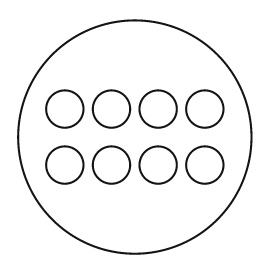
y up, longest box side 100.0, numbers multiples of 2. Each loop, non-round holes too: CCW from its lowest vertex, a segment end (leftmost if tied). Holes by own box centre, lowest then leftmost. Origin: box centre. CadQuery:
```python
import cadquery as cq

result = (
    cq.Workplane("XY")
    .moveTo(0.0, 0.0)
    .circle(50.0)
    .moveTo(-30.0, -12.0)
    .circle(8.0)
    .moveTo(-10.0, -12.0)
    .circle(8.0)
    .moveTo(10.0, -12.0)
    .circle(8.0)
    .moveTo(30.0, -12.0)
    .circle(8.0)
    .moveTo(-30.0, 12.0)
    .circle(8.0)
    .moveTo(-10.0, 12.0)
    .circle(8.0)
    .moveTo(10.0, 12.0)
    .circle(8.0)
    .moveTo(30.0, 12.0)
    .circle(8.0)
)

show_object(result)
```